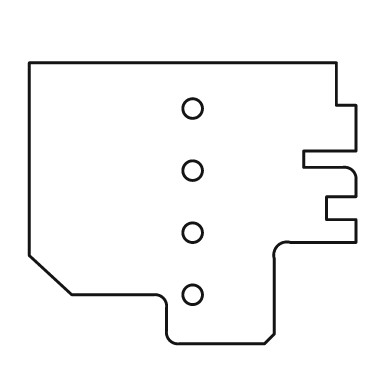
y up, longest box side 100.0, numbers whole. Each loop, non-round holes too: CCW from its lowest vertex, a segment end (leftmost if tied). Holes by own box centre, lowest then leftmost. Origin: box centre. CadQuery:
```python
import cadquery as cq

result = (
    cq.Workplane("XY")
    .moveTo(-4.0, -43.0)
    .lineTo(22.0, -43.0)
    .lineTo(25.0, -40.0)
    .lineTo(25.0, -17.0)
    .threePointArc((26.0, -13.0), (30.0, -12.0))
    .lineTo(50.0, -12.0)
    .lineTo(50.0, -5.0)
    .lineTo(41.0, -5.0)
    .lineTo(41.0, 2.0)
    .lineTo(50.0, 2.0)
    .lineTo(50.0, 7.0)
    .threePointArc((49.0, 10.0), (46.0, 11.0))
    .lineTo(34.0, 11.0)
    .lineTo(34.0, 16.0)
    .lineTo(50.0, 16.0)
    .lineTo(50.0, 30.0)
    .lineTo(44.0, 30.0)
    .lineTo(44.0, 43.0)
    .lineTo(-50.0, 43.0)
    .lineTo(-50.0, -16.0)
    .lineTo(-37.0, -28.0)
    .lineTo(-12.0, -28.0)
    .threePointArc((-9.0, -29.0), (-8.0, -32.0))
    .lineTo(-8.0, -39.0)
    .threePointArc((-7.0, -42.0), (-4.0, -43.0))
    .close()
    .moveTo(0.0, -28.0)
    .circle(3.0)
    .moveTo(0.0, -9.0)
    .circle(3.0)
    .moveTo(0.0, 10.0)
    .circle(3.0)
    .moveTo(0.0, 29.0)
    .circle(3.0)
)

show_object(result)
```